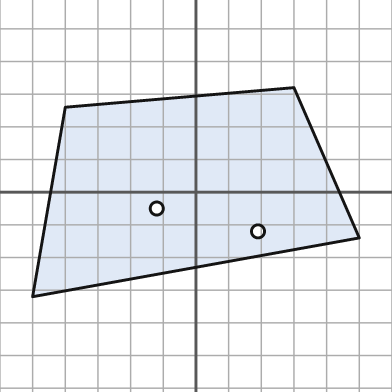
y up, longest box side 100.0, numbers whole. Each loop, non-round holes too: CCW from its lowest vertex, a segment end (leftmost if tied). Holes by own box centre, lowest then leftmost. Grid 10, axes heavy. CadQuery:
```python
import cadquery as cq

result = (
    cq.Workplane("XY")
    .moveTo(-50.0, -32.0)
    .lineTo(50.0, -14.0)
    .lineTo(30.0, 32.0)
    .lineTo(-40.0, 26.0)
    .close()
    .moveTo(19.0, -12.0)
    .circle(2.0)
    .moveTo(-12.0, -5.0)
    .circle(2.0)
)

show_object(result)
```